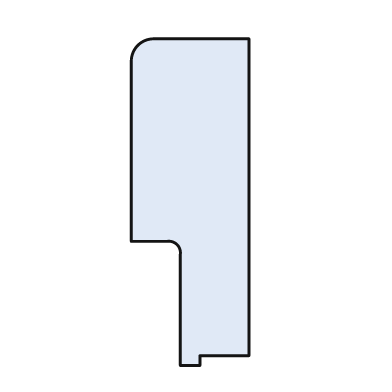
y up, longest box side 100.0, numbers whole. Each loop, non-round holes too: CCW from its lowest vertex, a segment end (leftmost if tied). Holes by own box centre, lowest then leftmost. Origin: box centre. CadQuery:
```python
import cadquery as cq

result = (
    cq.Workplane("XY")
    .moveTo(-3.0, -50.0)
    .lineTo(3.0, -50.0)
    .lineTo(3.0, -47.0)
    .lineTo(18.0, -47.0)
    .lineTo(18.0, 50.0)
    .lineTo(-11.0, 50.0)
    .threePointArc((-16.0, 48.0), (-18.0, 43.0))
    .lineTo(-18.0, -12.0)
    .lineTo(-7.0, -12.0)
    .threePointArc((-4.0, -13.0), (-3.0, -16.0))
    .close()
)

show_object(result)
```